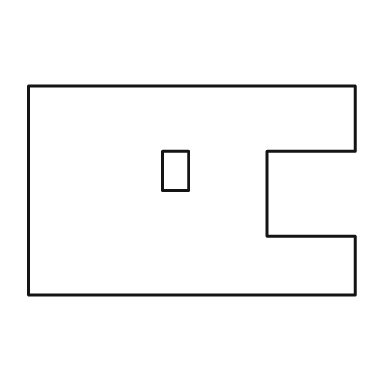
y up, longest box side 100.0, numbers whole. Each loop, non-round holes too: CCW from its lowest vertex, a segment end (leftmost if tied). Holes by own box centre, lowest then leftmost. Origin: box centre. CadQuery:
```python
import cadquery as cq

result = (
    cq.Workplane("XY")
    .moveTo(-50.0, -32.0)
    .lineTo(50.0, -32.0)
    .lineTo(50.0, -14.0)
    .lineTo(23.0, -14.0)
    .lineTo(23.0, 12.0)
    .lineTo(50.0, 12.0)
    .lineTo(50.0, 32.0)
    .lineTo(-50.0, 32.0)
    .close()
    .moveTo(-9.0, 0.0)
    .lineTo(-1.0, 0.0)
    .lineTo(-1.0, 12.0)
    .lineTo(-9.0, 12.0)
    .close()
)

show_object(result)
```